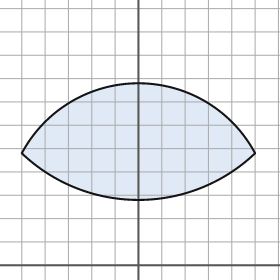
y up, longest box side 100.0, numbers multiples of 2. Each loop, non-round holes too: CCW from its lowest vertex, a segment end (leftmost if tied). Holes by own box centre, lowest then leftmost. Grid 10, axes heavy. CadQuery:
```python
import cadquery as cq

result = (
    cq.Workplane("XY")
    .moveTo(-50.0, 48.0)
    .threePointArc((0.0, 28.0), (50.0, 48.0))
    .threePointArc((0.0, 78.0), (-50.0, 48.0))
    .close()
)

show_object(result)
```